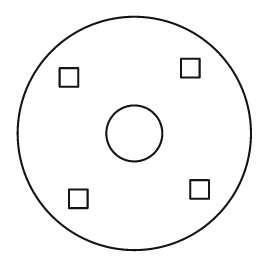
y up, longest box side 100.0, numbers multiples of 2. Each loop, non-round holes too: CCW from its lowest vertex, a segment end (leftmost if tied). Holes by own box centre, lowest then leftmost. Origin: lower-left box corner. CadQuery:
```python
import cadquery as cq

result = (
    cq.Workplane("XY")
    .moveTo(50.0, 50.0)
    .circle(50.0)
    .moveTo(22.0, 18.0)
    .lineTo(30.0, 18.0)
    .lineTo(30.0, 26.0)
    .lineTo(22.0, 26.0)
    .close()
    .moveTo(74.0, 22.0)
    .lineTo(82.0, 22.0)
    .lineTo(82.0, 30.0)
    .lineTo(74.0, 30.0)
    .close()
    .moveTo(50.0, 50.0)
    .circle(12.0)
    .moveTo(18.0, 70.0)
    .lineTo(26.0, 70.0)
    .lineTo(26.0, 78.0)
    .lineTo(18.0, 78.0)
    .close()
    .moveTo(70.0, 74.0)
    .lineTo(78.0, 74.0)
    .lineTo(78.0, 82.0)
    .lineTo(70.0, 82.0)
    .close()
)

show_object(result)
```